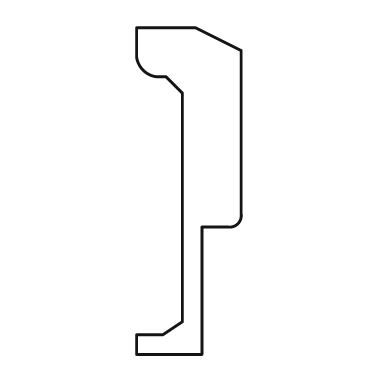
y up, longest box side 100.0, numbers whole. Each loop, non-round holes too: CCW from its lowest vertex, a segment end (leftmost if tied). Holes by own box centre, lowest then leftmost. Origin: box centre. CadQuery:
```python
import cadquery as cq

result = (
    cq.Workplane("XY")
    .moveTo(-16.0, -50.0)
    .lineTo(4.0, -50.0)
    .lineTo(4.0, -11.0)
    .lineTo(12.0, -11.0)
    .threePointArc((15.0, -10.0), (16.0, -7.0))
    .lineTo(16.0, 43.0)
    .lineTo(2.0, 50.0)
    .lineTo(-16.0, 50.0)
    .lineTo(-16.0, 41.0)
    .threePointArc((-14.0, 37.0), (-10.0, 35.0))
    .lineTo(-7.0, 35.0)
    .lineTo(-2.0, 30.0)
    .lineTo(-2.0, -40.0)
    .lineTo(-8.0, -44.0)
    .lineTo(-16.0, -44.0)
    .close()
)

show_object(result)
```